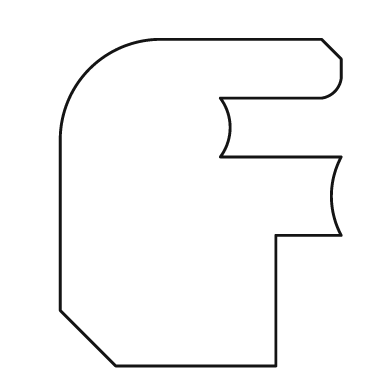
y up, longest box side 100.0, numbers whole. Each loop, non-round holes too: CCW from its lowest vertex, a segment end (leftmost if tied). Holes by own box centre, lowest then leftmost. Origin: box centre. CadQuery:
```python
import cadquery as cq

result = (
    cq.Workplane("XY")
    .moveTo(-26.0, -50.0)
    .lineTo(23.0, -50.0)
    .lineTo(23.0, -10.0)
    .lineTo(43.0, -10.0)
    .threePointArc((40.0, 2.0), (43.0, 14.0))
    .lineTo(6.0, 14.0)
    .threePointArc((9.0, 23.0), (6.0, 32.0))
    .lineTo(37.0, 32.0)
    .threePointArc((41.0, 34.0), (43.0, 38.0))
    .lineTo(43.0, 44.0)
    .lineTo(37.0, 50.0)
    .lineTo(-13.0, 50.0)
    .threePointArc((-34.0, 41.0), (-43.0, 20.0))
    .lineTo(-43.0, -33.0)
    .close()
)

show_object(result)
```